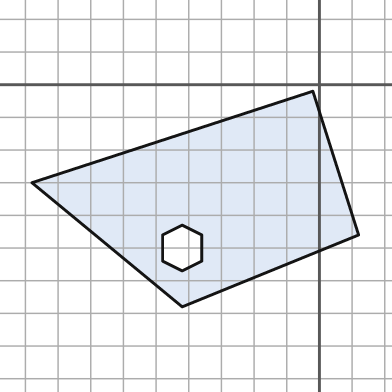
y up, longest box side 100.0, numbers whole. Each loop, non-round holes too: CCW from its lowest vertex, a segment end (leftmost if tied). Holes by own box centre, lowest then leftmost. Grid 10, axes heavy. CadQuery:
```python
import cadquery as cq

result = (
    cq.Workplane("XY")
    .moveTo(-42.0, -68.0)
    .lineTo(12.0, -46.0)
    .lineTo(-2.0, -2.0)
    .lineTo(-88.0, -30.0)
    .close()
    .moveTo(-42.0, -57.0)
    .lineTo(-36.0, -54.0)
    .lineTo(-36.0, -46.0)
    .lineTo(-42.0, -43.0)
    .lineTo(-48.0, -46.0)
    .lineTo(-48.0, -54.0)
    .close()
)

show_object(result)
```